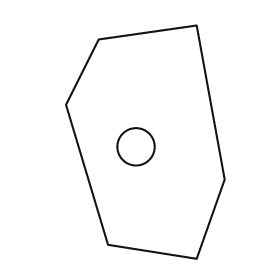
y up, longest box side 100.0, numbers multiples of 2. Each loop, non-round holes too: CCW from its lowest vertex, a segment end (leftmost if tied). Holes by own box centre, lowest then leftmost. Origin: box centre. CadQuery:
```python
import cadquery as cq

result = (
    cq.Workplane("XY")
    .moveTo(22.0, -50.0)
    .lineTo(34.0, -16.0)
    .lineTo(22.0, 50.0)
    .lineTo(-20.0, 44.0)
    .lineTo(-34.0, 16.0)
    .lineTo(-16.0, -44.0)
    .close()
    .moveTo(-4.0, -2.0)
    .circle(8.0)
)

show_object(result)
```